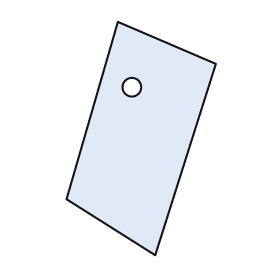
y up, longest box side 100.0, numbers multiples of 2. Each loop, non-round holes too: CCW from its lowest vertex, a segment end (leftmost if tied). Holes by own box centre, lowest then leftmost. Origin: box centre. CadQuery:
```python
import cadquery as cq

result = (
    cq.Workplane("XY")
    .moveTo(6.0, -50.0)
    .lineTo(32.0, 32.0)
    .lineTo(-10.0, 50.0)
    .lineTo(-32.0, -26.0)
    .close()
    .moveTo(-4.0, 22.0)
    .circle(4.0)
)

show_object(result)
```